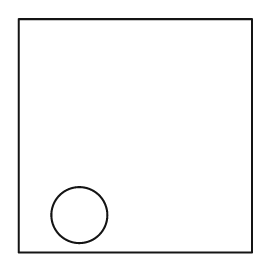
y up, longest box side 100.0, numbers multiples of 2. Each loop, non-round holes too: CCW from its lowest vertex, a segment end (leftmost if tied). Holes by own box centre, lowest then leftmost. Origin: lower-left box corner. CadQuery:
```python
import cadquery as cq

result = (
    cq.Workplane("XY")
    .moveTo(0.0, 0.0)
    .lineTo(100.0, 0.0)
    .lineTo(100.0, 100.0)
    .lineTo(0.0, 100.0)
    .close()
    .moveTo(26.0, 16.0)
    .circle(12.0)
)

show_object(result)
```